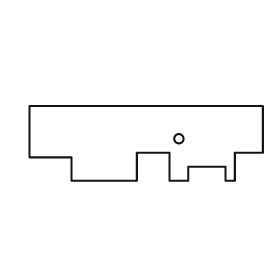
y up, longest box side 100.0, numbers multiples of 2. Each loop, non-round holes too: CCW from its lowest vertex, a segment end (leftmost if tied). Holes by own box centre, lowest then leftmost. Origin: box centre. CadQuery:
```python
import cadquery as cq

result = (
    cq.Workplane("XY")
    .moveTo(-32.0, -16.0)
    .lineTo(-4.0, -16.0)
    .lineTo(-4.0, -4.0)
    .lineTo(10.0, -4.0)
    .lineTo(10.0, -16.0)
    .lineTo(18.0, -16.0)
    .lineTo(18.0, -10.0)
    .lineTo(34.0, -10.0)
    .lineTo(34.0, -16.0)
    .lineTo(38.0, -16.0)
    .lineTo(38.0, -4.0)
    .lineTo(50.0, -4.0)
    .lineTo(50.0, 16.0)
    .lineTo(-50.0, 16.0)
    .lineTo(-50.0, -6.0)
    .lineTo(-32.0, -6.0)
    .close()
    .moveTo(14.0, 2.0)
    .circle(2.0)
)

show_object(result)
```